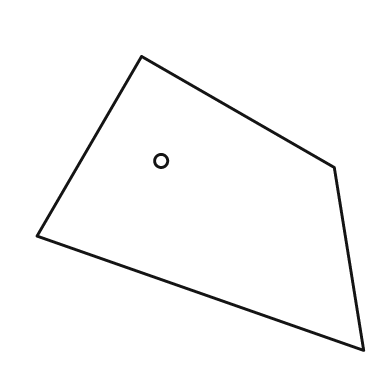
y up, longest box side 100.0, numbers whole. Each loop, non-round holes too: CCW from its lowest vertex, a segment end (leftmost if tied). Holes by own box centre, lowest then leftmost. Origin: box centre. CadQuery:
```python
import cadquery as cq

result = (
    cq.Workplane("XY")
    .moveTo(50.0, -45.0)
    .lineTo(41.0, 11.0)
    .lineTo(-18.0, 45.0)
    .lineTo(-50.0, -10.0)
    .close()
    .moveTo(-12.0, 13.0)
    .circle(2.0)
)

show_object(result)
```